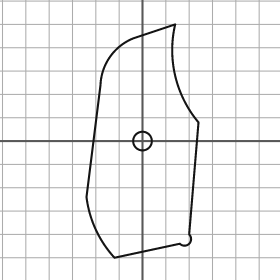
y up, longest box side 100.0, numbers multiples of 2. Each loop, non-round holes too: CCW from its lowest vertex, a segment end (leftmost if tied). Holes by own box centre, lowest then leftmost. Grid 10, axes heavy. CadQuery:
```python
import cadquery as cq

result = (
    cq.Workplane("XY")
    .moveTo(-12.0, -50.0)
    .lineTo(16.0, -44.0)
    .threePointArc((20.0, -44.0), (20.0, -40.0))
    .lineTo(24.0, 8.0)
    .threePointArc((14.0, 28.0), (14.0, 50.0))
    .lineTo(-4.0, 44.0)
    .threePointArc((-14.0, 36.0), (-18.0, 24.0))
    .lineTo(-24.0, -24.0)
    .threePointArc((-20.0, -38.0), (-12.0, -50.0))
    .close()
    .moveTo(0.0, 0.0)
    .circle(4.0)
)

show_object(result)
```